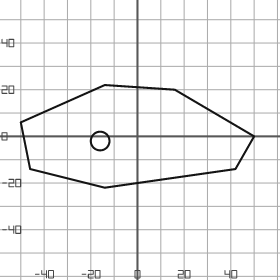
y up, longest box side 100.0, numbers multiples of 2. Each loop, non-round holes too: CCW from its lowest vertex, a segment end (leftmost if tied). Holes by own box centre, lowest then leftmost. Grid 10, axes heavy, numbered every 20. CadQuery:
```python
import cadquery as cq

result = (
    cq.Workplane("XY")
    .moveTo(-14.0, -22.0)
    .lineTo(42.0, -14.0)
    .lineTo(50.0, 0.0)
    .lineTo(16.0, 20.0)
    .lineTo(-14.0, 22.0)
    .lineTo(-50.0, 6.0)
    .lineTo(-46.0, -14.0)
    .close()
    .moveTo(-16.0, -2.0)
    .circle(4.0)
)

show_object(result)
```